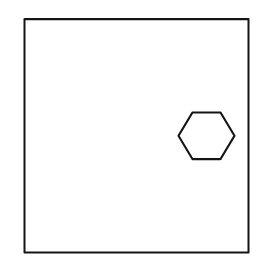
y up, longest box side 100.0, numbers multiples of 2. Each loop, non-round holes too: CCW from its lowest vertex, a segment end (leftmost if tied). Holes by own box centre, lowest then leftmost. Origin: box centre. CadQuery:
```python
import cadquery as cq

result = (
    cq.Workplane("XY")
    .moveTo(-48.0, -50.0)
    .lineTo(48.0, -50.0)
    .lineTo(48.0, 50.0)
    .lineTo(-48.0, 50.0)
    .close()
    .moveTo(24.0, -10.0)
    .lineTo(36.0, -10.0)
    .lineTo(42.0, 0.0)
    .lineTo(36.0, 10.0)
    .lineTo(24.0, 10.0)
    .lineTo(18.0, 0.0)
    .close()
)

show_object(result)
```